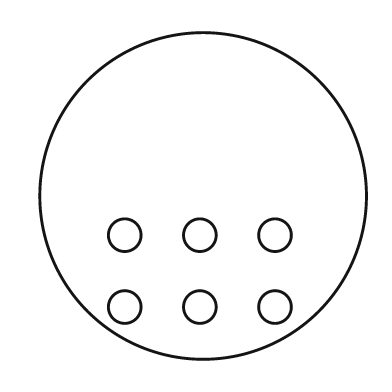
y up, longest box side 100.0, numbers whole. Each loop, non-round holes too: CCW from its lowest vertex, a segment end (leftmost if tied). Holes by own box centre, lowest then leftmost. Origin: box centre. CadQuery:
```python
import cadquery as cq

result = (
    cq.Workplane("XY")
    .moveTo(0.0, 0.0)
    .circle(50.0)
    .moveTo(-24.0, -34.0)
    .circle(5.0)
    .moveTo(-1.0, -34.0)
    .circle(5.0)
    .moveTo(22.0, -34.0)
    .circle(5.0)
    .moveTo(-24.0, -12.0)
    .circle(5.0)
    .moveTo(-1.0, -12.0)
    .circle(5.0)
    .moveTo(22.0, -12.0)
    .circle(5.0)
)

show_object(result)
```